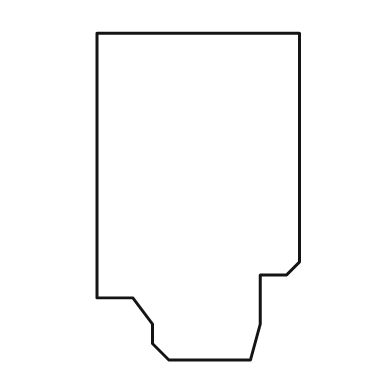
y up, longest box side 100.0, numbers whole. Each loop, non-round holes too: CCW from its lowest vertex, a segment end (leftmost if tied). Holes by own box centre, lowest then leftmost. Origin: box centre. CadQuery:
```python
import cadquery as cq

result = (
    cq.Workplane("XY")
    .moveTo(-9.0, -50.0)
    .lineTo(16.0, -50.0)
    .lineTo(19.0, -39.0)
    .lineTo(19.0, -24.0)
    .lineTo(27.0, -24.0)
    .lineTo(31.0, -20.0)
    .lineTo(31.0, 50.0)
    .lineTo(-31.0, 50.0)
    .lineTo(-31.0, -31.0)
    .lineTo(-20.0, -31.0)
    .lineTo(-14.0, -39.0)
    .lineTo(-14.0, -45.0)
    .close()
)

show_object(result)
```